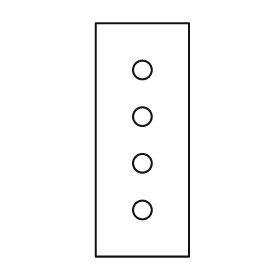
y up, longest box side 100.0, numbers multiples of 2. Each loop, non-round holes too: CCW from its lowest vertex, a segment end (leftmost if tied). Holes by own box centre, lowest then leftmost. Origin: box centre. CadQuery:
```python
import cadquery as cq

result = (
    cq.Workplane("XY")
    .moveTo(-20.0, -50.0)
    .lineTo(20.0, -50.0)
    .lineTo(20.0, 50.0)
    .lineTo(-20.0, 50.0)
    .close()
    .moveTo(0.0, -30.0)
    .circle(4.0)
    .moveTo(0.0, -10.0)
    .circle(4.0)
    .moveTo(0.0, 10.0)
    .circle(4.0)
    .moveTo(0.0, 30.0)
    .circle(4.0)
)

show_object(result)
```